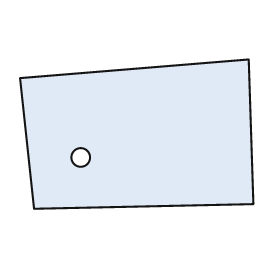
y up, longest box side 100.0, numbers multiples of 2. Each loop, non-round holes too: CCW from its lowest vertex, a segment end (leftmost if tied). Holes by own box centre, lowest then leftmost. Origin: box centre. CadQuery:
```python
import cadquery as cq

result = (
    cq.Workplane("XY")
    .moveTo(-44.0, -32.0)
    .lineTo(50.0, -30.0)
    .lineTo(48.0, 32.0)
    .lineTo(-50.0, 24.0)
    .close()
    .moveTo(-24.0, -10.0)
    .circle(4.0)
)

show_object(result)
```